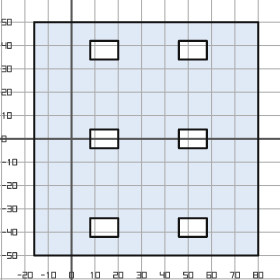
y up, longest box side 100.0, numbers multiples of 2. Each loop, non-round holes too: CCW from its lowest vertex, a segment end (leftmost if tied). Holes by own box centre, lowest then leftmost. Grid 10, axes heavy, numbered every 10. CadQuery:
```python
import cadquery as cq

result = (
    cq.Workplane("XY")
    .moveTo(-16.0, -50.0)
    .lineTo(80.0, -50.0)
    .lineTo(80.0, 50.0)
    .lineTo(-16.0, 50.0)
    .close()
    .moveTo(8.0, -42.0)
    .lineTo(20.0, -42.0)
    .lineTo(20.0, -34.0)
    .lineTo(8.0, -34.0)
    .close()
    .moveTo(46.0, -42.0)
    .lineTo(58.0, -42.0)
    .lineTo(58.0, -34.0)
    .lineTo(46.0, -34.0)
    .close()
    .moveTo(8.0, -4.0)
    .lineTo(20.0, -4.0)
    .lineTo(20.0, 4.0)
    .lineTo(8.0, 4.0)
    .close()
    .moveTo(46.0, -4.0)
    .lineTo(58.0, -4.0)
    .lineTo(58.0, 4.0)
    .lineTo(46.0, 4.0)
    .close()
    .moveTo(8.0, 34.0)
    .lineTo(20.0, 34.0)
    .lineTo(20.0, 42.0)
    .lineTo(8.0, 42.0)
    .close()
    .moveTo(46.0, 34.0)
    .lineTo(58.0, 34.0)
    .lineTo(58.0, 42.0)
    .lineTo(46.0, 42.0)
    .close()
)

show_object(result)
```